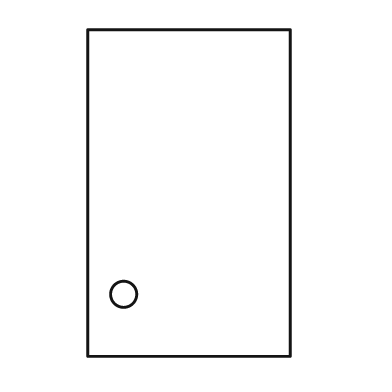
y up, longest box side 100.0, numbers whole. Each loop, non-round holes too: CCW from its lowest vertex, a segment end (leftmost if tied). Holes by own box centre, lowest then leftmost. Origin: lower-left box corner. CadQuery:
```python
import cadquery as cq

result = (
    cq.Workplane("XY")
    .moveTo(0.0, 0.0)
    .lineTo(62.0, 0.0)
    .lineTo(62.0, 100.0)
    .lineTo(0.0, 100.0)
    .close()
    .moveTo(11.0, 19.0)
    .circle(4.0)
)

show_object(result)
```